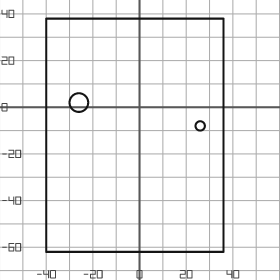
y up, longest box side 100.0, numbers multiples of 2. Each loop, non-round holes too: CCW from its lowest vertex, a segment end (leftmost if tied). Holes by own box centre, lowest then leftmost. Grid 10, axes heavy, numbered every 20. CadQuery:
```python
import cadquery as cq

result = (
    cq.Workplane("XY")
    .moveTo(-40.0, -62.0)
    .lineTo(36.0, -62.0)
    .lineTo(36.0, 38.0)
    .lineTo(-40.0, 38.0)
    .close()
    .moveTo(26.0, -8.0)
    .circle(2.0)
    .moveTo(-26.0, 2.0)
    .circle(4.0)
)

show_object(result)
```